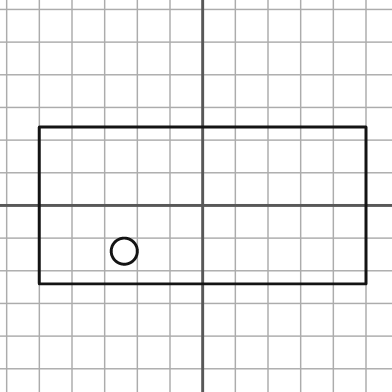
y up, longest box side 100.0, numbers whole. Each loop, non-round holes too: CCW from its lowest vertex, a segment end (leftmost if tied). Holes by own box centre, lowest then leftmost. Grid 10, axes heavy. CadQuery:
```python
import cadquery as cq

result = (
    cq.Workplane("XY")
    .moveTo(-50.0, -24.0)
    .lineTo(50.0, -24.0)
    .lineTo(50.0, 24.0)
    .lineTo(-50.0, 24.0)
    .close()
    .moveTo(-24.0, -14.0)
    .circle(4.0)
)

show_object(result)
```